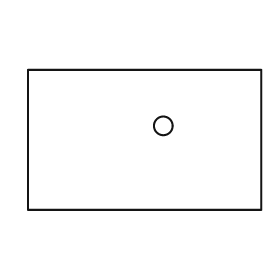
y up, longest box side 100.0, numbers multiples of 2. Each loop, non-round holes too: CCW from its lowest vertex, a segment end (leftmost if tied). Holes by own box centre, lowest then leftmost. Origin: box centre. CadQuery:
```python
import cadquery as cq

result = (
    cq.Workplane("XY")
    .moveTo(-50.0, -30.0)
    .lineTo(50.0, -30.0)
    .lineTo(50.0, 30.0)
    .lineTo(-50.0, 30.0)
    .close()
    .moveTo(8.0, 6.0)
    .circle(4.0)
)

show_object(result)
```